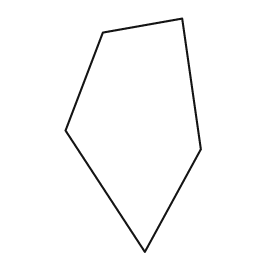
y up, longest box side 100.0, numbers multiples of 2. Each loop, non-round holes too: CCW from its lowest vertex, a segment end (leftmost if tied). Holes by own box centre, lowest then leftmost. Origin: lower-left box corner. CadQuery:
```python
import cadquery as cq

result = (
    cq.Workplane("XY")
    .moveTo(34.0, 0.0)
    .lineTo(58.0, 44.0)
    .lineTo(50.0, 100.0)
    .lineTo(16.0, 94.0)
    .lineTo(0.0, 52.0)
    .close()
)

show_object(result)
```